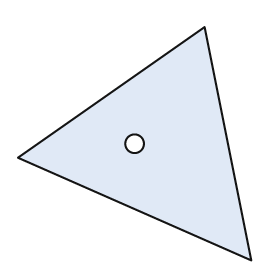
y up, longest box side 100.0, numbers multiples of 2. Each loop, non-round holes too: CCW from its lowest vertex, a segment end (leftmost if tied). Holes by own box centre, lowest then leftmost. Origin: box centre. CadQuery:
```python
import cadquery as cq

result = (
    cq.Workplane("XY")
    .moveTo(50.0, -50.0)
    .lineTo(30.0, 50.0)
    .lineTo(-50.0, -6.0)
    .close()
    .moveTo(0.0, 0.0)
    .circle(4.0)
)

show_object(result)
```